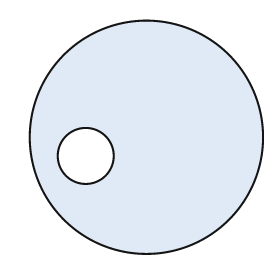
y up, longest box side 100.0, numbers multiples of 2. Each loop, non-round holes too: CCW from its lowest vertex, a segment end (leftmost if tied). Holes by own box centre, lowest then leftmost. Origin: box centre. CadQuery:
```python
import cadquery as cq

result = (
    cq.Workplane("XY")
    .moveTo(0.0, 0.0)
    .circle(50.0)
    .moveTo(-26.0, -8.0)
    .circle(12.0)
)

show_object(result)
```